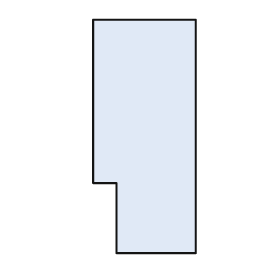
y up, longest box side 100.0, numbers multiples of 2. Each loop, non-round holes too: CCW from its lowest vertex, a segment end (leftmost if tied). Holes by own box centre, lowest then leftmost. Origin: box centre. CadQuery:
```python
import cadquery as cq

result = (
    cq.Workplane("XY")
    .moveTo(-12.0, -50.0)
    .lineTo(22.0, -50.0)
    .lineTo(22.0, 50.0)
    .lineTo(-22.0, 50.0)
    .lineTo(-22.0, -20.0)
    .lineTo(-12.0, -20.0)
    .close()
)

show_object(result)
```